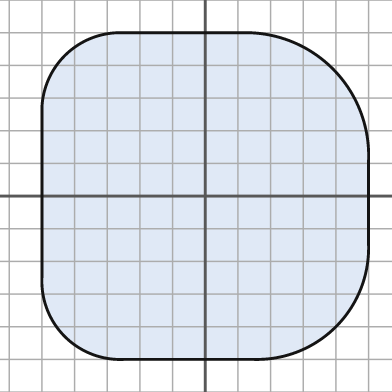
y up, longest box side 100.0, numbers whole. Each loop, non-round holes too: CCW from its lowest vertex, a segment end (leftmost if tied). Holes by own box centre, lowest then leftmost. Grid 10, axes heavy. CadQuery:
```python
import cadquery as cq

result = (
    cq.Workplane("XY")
    .moveTo(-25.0, -50.0)
    .lineTo(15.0, -50.0)
    .threePointArc((40.0, -40.0), (50.0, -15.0))
    .lineTo(50.0, 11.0)
    .threePointArc((39.0, 39.0), (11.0, 50.0))
    .lineTo(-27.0, 50.0)
    .threePointArc((-43.0, 43.0), (-50.0, 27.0))
    .lineTo(-50.0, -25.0)
    .threePointArc((-43.0, -43.0), (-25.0, -50.0))
    .close()
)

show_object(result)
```